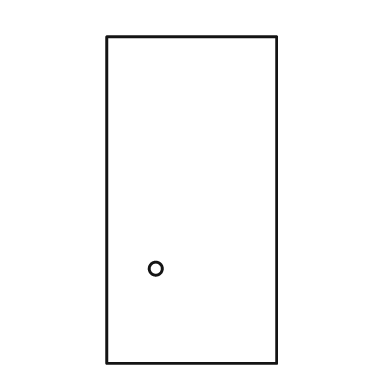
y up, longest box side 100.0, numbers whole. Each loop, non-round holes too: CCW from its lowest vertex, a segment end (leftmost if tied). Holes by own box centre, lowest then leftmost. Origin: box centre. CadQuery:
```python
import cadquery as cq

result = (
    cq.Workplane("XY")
    .moveTo(-26.0, -50.0)
    .lineTo(26.0, -50.0)
    .lineTo(26.0, 50.0)
    .lineTo(-26.0, 50.0)
    .close()
    .moveTo(-11.0, -21.0)
    .circle(2.0)
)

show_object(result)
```